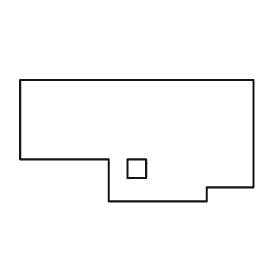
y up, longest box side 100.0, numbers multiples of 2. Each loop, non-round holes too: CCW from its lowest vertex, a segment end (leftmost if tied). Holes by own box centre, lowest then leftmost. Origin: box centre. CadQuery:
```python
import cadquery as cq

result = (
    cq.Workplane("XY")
    .moveTo(-12.0, -26.0)
    .lineTo(30.0, -26.0)
    .lineTo(30.0, -20.0)
    .lineTo(50.0, -20.0)
    .lineTo(50.0, 26.0)
    .lineTo(-50.0, 26.0)
    .lineTo(-50.0, -8.0)
    .lineTo(-12.0, -8.0)
    .close()
    .moveTo(-4.0, -16.0)
    .lineTo(4.0, -16.0)
    .lineTo(4.0, -8.0)
    .lineTo(-4.0, -8.0)
    .close()
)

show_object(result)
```